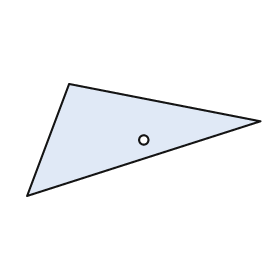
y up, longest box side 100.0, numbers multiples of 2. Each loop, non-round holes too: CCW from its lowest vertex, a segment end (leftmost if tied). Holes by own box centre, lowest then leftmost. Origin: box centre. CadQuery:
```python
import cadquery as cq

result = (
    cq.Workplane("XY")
    .moveTo(-50.0, -24.0)
    .lineTo(50.0, 8.0)
    .lineTo(-32.0, 24.0)
    .close()
    .moveTo(0.0, 0.0)
    .circle(2.0)
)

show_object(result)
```